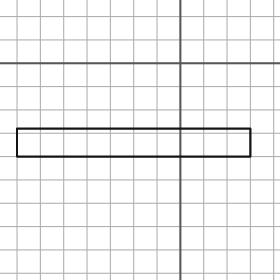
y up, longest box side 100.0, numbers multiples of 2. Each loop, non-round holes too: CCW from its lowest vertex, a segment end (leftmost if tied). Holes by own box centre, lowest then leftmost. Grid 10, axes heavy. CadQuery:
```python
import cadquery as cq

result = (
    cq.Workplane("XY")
    .moveTo(-70.0, -40.0)
    .lineTo(30.0, -40.0)
    .lineTo(30.0, -28.0)
    .lineTo(-70.0, -28.0)
    .close()
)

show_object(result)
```